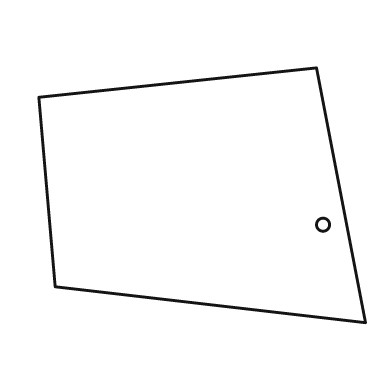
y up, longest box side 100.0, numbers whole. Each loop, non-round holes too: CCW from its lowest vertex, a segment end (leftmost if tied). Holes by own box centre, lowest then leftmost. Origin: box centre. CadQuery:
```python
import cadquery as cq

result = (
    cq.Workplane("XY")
    .moveTo(50.0, -39.0)
    .lineTo(35.0, 39.0)
    .lineTo(-50.0, 30.0)
    .lineTo(-45.0, -28.0)
    .close()
    .moveTo(37.0, -9.0)
    .circle(2.0)
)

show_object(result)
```